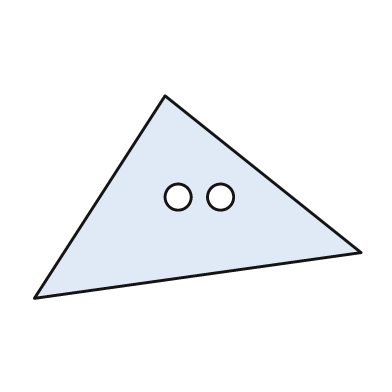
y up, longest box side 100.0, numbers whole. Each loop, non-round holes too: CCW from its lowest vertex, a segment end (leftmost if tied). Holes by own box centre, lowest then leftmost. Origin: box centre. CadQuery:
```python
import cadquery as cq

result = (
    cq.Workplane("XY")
    .moveTo(-50.0, -31.0)
    .lineTo(50.0, -17.0)
    .lineTo(-10.0, 31.0)
    .close()
    .moveTo(-6.0, 0.0)
    .circle(4.0)
    .moveTo(7.0, 0.0)
    .circle(4.0)
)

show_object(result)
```